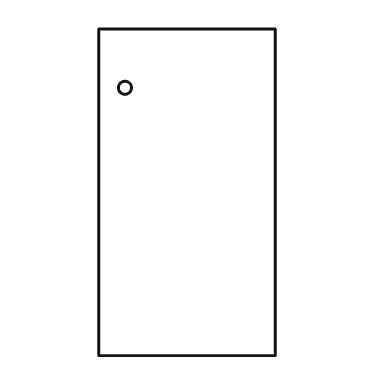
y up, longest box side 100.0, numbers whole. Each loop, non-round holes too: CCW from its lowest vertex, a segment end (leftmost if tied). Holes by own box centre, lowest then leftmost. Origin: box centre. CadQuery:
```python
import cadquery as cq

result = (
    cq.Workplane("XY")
    .moveTo(-27.0, -50.0)
    .lineTo(27.0, -50.0)
    .lineTo(27.0, 50.0)
    .lineTo(-27.0, 50.0)
    .close()
    .moveTo(-19.0, 32.0)
    .circle(2.0)
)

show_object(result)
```